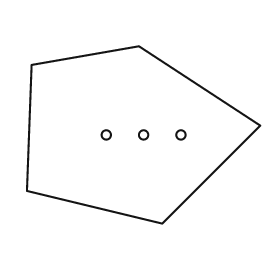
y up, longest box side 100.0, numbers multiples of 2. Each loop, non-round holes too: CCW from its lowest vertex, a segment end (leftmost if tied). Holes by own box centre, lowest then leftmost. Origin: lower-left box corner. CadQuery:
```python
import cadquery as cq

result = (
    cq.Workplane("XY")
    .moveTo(58.0, 0.0)
    .lineTo(100.0, 42.0)
    .lineTo(48.0, 76.0)
    .lineTo(2.0, 68.0)
    .lineTo(0.0, 14.0)
    .close()
    .moveTo(34.0, 38.0)
    .circle(2.0)
    .moveTo(50.0, 38.0)
    .circle(2.0)
    .moveTo(66.0, 38.0)
    .circle(2.0)
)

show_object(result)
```